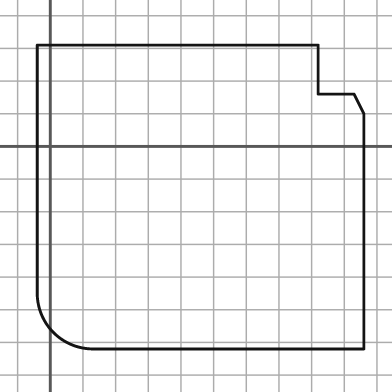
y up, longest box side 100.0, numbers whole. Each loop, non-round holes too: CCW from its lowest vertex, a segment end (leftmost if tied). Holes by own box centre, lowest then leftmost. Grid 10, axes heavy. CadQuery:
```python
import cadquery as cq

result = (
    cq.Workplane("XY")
    .moveTo(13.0, -62.0)
    .lineTo(96.0, -62.0)
    .lineTo(96.0, 10.0)
    .lineTo(93.0, 16.0)
    .lineTo(82.0, 16.0)
    .lineTo(82.0, 31.0)
    .lineTo(-4.0, 31.0)
    .lineTo(-4.0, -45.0)
    .threePointArc((1.0, -57.0), (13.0, -62.0))
    .close()
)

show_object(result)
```